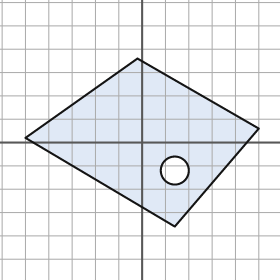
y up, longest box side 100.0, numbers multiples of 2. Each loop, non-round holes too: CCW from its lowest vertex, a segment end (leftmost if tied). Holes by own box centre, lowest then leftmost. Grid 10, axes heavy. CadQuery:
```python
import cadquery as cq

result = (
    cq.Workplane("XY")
    .moveTo(14.0, -36.0)
    .lineTo(50.0, 6.0)
    .lineTo(-2.0, 36.0)
    .lineTo(-50.0, 2.0)
    .close()
    .moveTo(14.0, -12.0)
    .circle(6.0)
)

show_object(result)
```